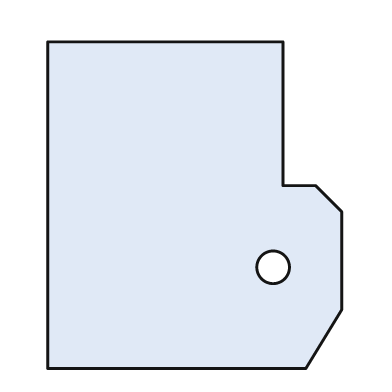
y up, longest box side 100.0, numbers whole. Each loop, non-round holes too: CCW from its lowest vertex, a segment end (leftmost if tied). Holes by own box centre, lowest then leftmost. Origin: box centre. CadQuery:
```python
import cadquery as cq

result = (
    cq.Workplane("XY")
    .moveTo(-45.0, -50.0)
    .lineTo(34.0, -50.0)
    .lineTo(45.0, -32.0)
    .lineTo(45.0, -2.0)
    .lineTo(37.0, 6.0)
    .lineTo(27.0, 6.0)
    .lineTo(27.0, 50.0)
    .lineTo(-45.0, 50.0)
    .close()
    .moveTo(24.0, -19.0)
    .circle(5.0)
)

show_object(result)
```